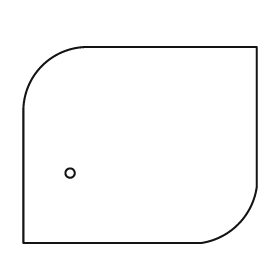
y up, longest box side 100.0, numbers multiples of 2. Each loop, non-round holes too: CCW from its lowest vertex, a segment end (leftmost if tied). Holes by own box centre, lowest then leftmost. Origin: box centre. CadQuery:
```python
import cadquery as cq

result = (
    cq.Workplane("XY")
    .moveTo(-50.0, -42.0)
    .lineTo(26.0, -42.0)
    .threePointArc((42.0, -34.0), (50.0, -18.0))
    .lineTo(50.0, 42.0)
    .lineTo(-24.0, 42.0)
    .threePointArc((-42.0, 34.0), (-50.0, 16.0))
    .close()
    .moveTo(-30.0, -12.0)
    .circle(2.0)
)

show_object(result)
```